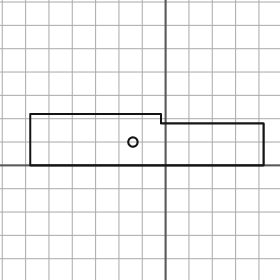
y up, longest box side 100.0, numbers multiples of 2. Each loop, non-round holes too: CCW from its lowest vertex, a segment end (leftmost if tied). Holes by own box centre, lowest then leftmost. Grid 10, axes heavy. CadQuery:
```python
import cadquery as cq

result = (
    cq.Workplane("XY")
    .moveTo(-58.0, 0.0)
    .lineTo(42.0, 0.0)
    .lineTo(42.0, 18.0)
    .lineTo(-2.0, 18.0)
    .lineTo(-2.0, 22.0)
    .lineTo(-58.0, 22.0)
    .close()
    .moveTo(-14.0, 10.0)
    .circle(2.0)
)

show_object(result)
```